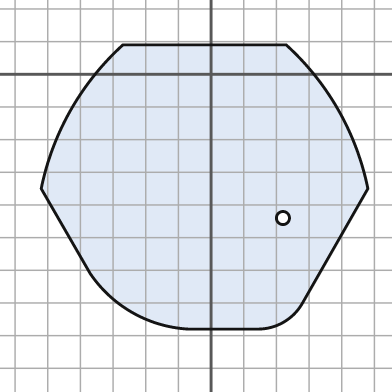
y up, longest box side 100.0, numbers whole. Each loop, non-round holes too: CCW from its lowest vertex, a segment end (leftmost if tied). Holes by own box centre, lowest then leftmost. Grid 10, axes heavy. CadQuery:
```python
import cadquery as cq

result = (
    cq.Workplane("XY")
    .moveTo(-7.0, -78.0)
    .lineTo(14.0, -78.0)
    .threePointArc((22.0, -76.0), (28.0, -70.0))
    .lineTo(48.0, -35.0)
    .threePointArc((39.0, -11.0), (23.0, 9.0))
    .lineTo(-27.0, 9.0)
    .threePointArc((-43.0, -11.0), (-52.0, -35.0))
    .lineTo(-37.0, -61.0)
    .threePointArc((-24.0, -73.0), (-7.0, -78.0))
    .close()
    .moveTo(22.0, -44.0)
    .circle(2.0)
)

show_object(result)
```